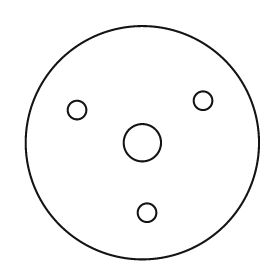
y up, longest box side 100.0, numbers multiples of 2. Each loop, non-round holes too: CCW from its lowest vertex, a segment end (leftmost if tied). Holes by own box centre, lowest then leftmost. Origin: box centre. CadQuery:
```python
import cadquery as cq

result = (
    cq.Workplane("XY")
    .moveTo(0.0, 0.0)
    .circle(50.0)
    .moveTo(2.0, -30.0)
    .circle(4.0)
    .moveTo(0.0, 0.0)
    .circle(8.0)
    .moveTo(-28.0, 14.0)
    .circle(4.0)
    .moveTo(26.0, 18.0)
    .circle(4.0)
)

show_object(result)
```